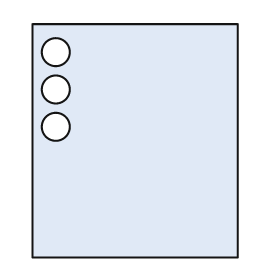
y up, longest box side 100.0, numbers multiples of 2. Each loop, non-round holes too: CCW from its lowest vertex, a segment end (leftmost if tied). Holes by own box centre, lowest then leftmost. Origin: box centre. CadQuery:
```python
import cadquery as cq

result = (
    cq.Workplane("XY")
    .moveTo(-44.0, -50.0)
    .lineTo(44.0, -50.0)
    .lineTo(44.0, 50.0)
    .lineTo(-44.0, 50.0)
    .close()
    .moveTo(-34.0, 6.0)
    .circle(6.0)
    .moveTo(-34.0, 22.0)
    .circle(6.0)
    .moveTo(-34.0, 38.0)
    .circle(6.0)
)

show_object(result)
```